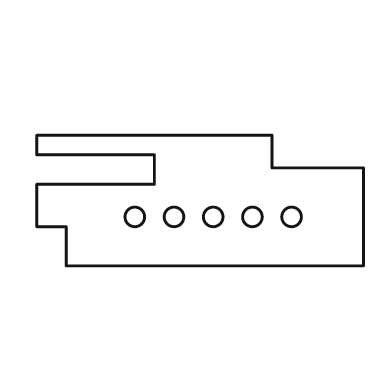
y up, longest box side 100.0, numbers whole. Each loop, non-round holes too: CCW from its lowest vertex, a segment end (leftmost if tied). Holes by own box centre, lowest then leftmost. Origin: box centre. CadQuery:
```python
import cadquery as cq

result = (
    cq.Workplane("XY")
    .moveTo(-41.0, -20.0)
    .lineTo(50.0, -20.0)
    .lineTo(50.0, 10.0)
    .lineTo(22.0, 10.0)
    .lineTo(22.0, 20.0)
    .lineTo(-50.0, 20.0)
    .lineTo(-50.0, 14.0)
    .lineTo(-14.0, 14.0)
    .lineTo(-14.0, 5.0)
    .lineTo(-50.0, 5.0)
    .lineTo(-50.0, -8.0)
    .lineTo(-41.0, -8.0)
    .close()
    .moveTo(-20.0, -5.0)
    .circle(3.0)
    .moveTo(-8.0, -5.0)
    .circle(3.0)
    .moveTo(4.0, -5.0)
    .circle(3.0)
    .moveTo(16.0, -5.0)
    .circle(3.0)
    .moveTo(28.0, -5.0)
    .circle(3.0)
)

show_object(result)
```